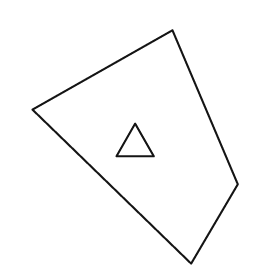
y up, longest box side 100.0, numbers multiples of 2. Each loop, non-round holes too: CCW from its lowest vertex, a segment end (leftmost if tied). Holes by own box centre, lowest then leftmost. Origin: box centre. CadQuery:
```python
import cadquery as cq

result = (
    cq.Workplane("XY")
    .moveTo(24.0, -50.0)
    .lineTo(44.0, -16.0)
    .lineTo(16.0, 50.0)
    .lineTo(-44.0, 16.0)
    .close()
    .moveTo(-8.0, -4.0)
    .lineTo(8.0, -4.0)
    .lineTo(0.0, 10.0)
    .close()
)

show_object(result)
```